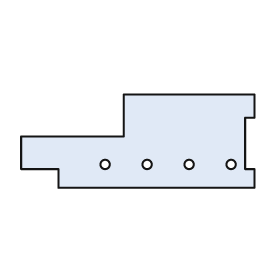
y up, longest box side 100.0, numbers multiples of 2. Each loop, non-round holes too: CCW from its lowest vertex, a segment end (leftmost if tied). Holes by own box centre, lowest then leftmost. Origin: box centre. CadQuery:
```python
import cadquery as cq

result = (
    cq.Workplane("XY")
    .moveTo(-34.0, -20.0)
    .lineTo(50.0, -20.0)
    .lineTo(50.0, -12.0)
    .lineTo(46.0, -12.0)
    .lineTo(46.0, 10.0)
    .lineTo(50.0, 10.0)
    .lineTo(50.0, 20.0)
    .lineTo(-6.0, 20.0)
    .lineTo(-6.0, 2.0)
    .lineTo(-50.0, 2.0)
    .lineTo(-50.0, -12.0)
    .lineTo(-34.0, -12.0)
    .close()
    .moveTo(-14.0, -10.0)
    .circle(2.0)
    .moveTo(4.0, -10.0)
    .circle(2.0)
    .moveTo(22.0, -10.0)
    .circle(2.0)
    .moveTo(40.0, -10.0)
    .circle(2.0)
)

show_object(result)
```